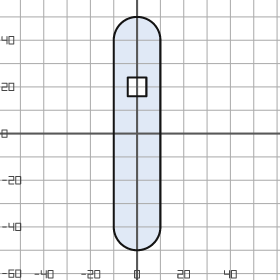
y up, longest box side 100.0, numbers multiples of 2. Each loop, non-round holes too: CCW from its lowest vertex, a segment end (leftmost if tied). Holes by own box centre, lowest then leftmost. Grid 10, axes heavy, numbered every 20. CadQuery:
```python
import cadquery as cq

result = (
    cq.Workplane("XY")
    .moveTo(-10.0, -40.0)
    .threePointArc((0.0, -50.0), (10.0, -40.0))
    .lineTo(10.0, 40.0)
    .threePointArc((0.0, 50.0), (-10.0, 40.0))
    .close()
    .moveTo(-4.0, 16.0)
    .lineTo(4.0, 16.0)
    .lineTo(4.0, 24.0)
    .lineTo(-4.0, 24.0)
    .close()
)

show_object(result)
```